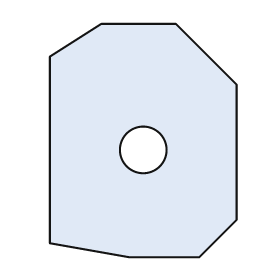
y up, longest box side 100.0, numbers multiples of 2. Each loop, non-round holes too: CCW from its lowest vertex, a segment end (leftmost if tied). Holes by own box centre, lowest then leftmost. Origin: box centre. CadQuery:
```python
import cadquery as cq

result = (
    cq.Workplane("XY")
    .moveTo(-6.0, -50.0)
    .lineTo(24.0, -50.0)
    .lineTo(40.0, -34.0)
    .lineTo(40.0, 24.0)
    .lineTo(14.0, 50.0)
    .lineTo(-18.0, 50.0)
    .lineTo(-40.0, 36.0)
    .lineTo(-40.0, -44.0)
    .close()
    .moveTo(0.0, -4.0)
    .circle(10.0)
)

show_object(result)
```